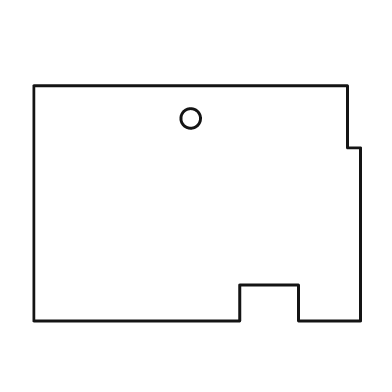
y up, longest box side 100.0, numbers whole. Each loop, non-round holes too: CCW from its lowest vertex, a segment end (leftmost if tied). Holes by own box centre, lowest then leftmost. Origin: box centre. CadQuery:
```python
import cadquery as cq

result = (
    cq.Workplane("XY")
    .moveTo(-50.0, -36.0)
    .lineTo(13.0, -36.0)
    .lineTo(13.0, -25.0)
    .lineTo(31.0, -25.0)
    .lineTo(31.0, -36.0)
    .lineTo(50.0, -36.0)
    .lineTo(50.0, 17.0)
    .lineTo(46.0, 17.0)
    .lineTo(46.0, 36.0)
    .lineTo(-50.0, 36.0)
    .close()
    .moveTo(-2.0, 26.0)
    .circle(3.0)
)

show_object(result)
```